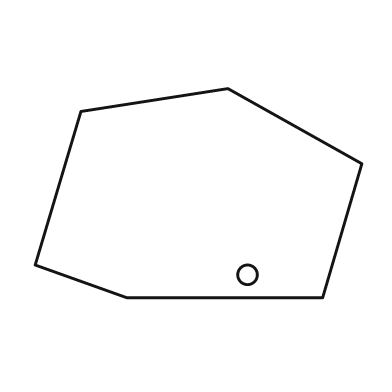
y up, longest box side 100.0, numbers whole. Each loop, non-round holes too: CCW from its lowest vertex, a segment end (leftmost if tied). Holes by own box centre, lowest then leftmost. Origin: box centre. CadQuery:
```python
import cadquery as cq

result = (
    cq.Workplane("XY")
    .moveTo(-22.0, -32.0)
    .lineTo(38.0, -32.0)
    .lineTo(50.0, 9.0)
    .lineTo(9.0, 32.0)
    .lineTo(-36.0, 25.0)
    .lineTo(-50.0, -22.0)
    .close()
    .moveTo(15.0, -25.0)
    .circle(3.0)
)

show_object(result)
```